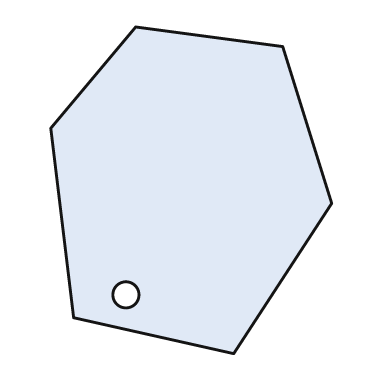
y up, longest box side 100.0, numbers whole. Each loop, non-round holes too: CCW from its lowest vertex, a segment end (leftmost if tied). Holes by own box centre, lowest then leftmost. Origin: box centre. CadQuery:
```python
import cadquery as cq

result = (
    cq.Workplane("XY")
    .moveTo(13.0, -50.0)
    .lineTo(43.0, -4.0)
    .lineTo(28.0, 44.0)
    .lineTo(-17.0, 50.0)
    .lineTo(-43.0, 19.0)
    .lineTo(-36.0, -39.0)
    .close()
    .moveTo(-20.0, -32.0)
    .circle(4.0)
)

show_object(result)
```